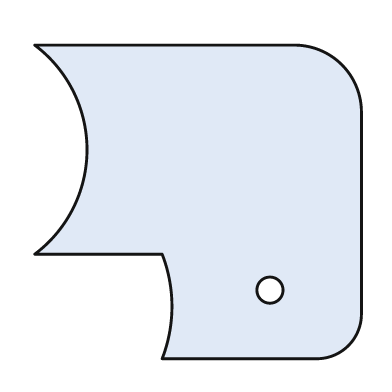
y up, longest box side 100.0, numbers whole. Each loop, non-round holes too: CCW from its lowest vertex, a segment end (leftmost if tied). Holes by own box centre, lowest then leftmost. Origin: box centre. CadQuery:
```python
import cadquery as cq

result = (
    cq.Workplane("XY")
    .moveTo(-11.0, -48.0)
    .lineTo(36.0, -48.0)
    .threePointArc((46.0, -44.0), (50.0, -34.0))
    .lineTo(50.0, 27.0)
    .threePointArc((44.0, 42.0), (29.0, 48.0))
    .lineTo(-50.0, 48.0)
    .threePointArc((-34.0, 16.0), (-50.0, -16.0))
    .lineTo(-11.0, -16.0)
    .threePointArc((-8.0, -32.0), (-11.0, -48.0))
    .close()
    .moveTo(22.0, -27.0)
    .circle(4.0)
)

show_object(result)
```